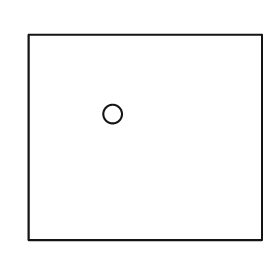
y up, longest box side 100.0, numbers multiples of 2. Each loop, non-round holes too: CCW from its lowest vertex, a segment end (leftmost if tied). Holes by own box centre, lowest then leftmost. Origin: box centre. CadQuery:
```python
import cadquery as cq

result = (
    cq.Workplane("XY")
    .moveTo(-50.0, -44.0)
    .lineTo(50.0, -44.0)
    .lineTo(50.0, 44.0)
    .lineTo(-50.0, 44.0)
    .close()
    .moveTo(-14.0, 10.0)
    .circle(4.0)
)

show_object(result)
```